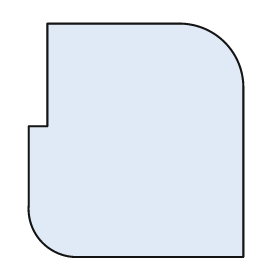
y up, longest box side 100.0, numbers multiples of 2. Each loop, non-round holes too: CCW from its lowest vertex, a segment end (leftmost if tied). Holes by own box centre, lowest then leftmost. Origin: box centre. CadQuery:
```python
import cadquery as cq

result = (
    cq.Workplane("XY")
    .moveTo(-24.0, -50.0)
    .lineTo(46.0, -50.0)
    .lineTo(46.0, 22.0)
    .threePointArc((38.0, 42.0), (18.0, 50.0))
    .lineTo(-38.0, 50.0)
    .lineTo(-38.0, 6.0)
    .lineTo(-46.0, 6.0)
    .lineTo(-46.0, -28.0)
    .threePointArc((-40.0, -44.0), (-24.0, -50.0))
    .close()
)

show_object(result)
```